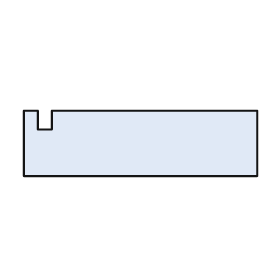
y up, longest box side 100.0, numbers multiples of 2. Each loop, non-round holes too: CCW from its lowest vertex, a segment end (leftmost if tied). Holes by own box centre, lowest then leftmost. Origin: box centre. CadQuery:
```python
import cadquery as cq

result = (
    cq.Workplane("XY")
    .moveTo(-50.0, -14.0)
    .lineTo(50.0, -14.0)
    .lineTo(50.0, 14.0)
    .lineTo(-38.0, 14.0)
    .lineTo(-38.0, 6.0)
    .lineTo(-44.0, 6.0)
    .lineTo(-44.0, 14.0)
    .lineTo(-50.0, 14.0)
    .close()
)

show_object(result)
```